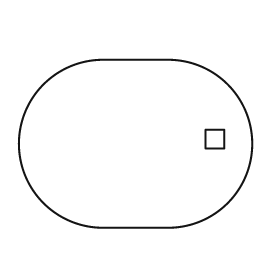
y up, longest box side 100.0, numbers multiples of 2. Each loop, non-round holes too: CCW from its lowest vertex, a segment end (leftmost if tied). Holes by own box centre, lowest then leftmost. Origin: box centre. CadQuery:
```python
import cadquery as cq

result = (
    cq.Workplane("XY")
    .moveTo(-14.0, -36.0)
    .lineTo(14.0, -36.0)
    .threePointArc((50.0, 0.0), (14.0, 36.0))
    .lineTo(-14.0, 36.0)
    .threePointArc((-50.0, 0.0), (-14.0, -36.0))
    .close()
    .moveTo(30.0, -2.0)
    .lineTo(38.0, -2.0)
    .lineTo(38.0, 6.0)
    .lineTo(30.0, 6.0)
    .close()
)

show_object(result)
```